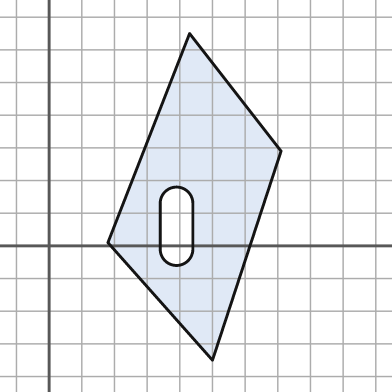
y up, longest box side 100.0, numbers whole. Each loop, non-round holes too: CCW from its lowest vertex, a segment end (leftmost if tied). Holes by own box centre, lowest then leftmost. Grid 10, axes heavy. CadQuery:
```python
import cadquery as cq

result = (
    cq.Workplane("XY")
    .moveTo(50.0, -35.0)
    .lineTo(71.0, 29.0)
    .lineTo(43.0, 65.0)
    .lineTo(18.0, 1.0)
    .close()
    .moveTo(34.0, -1.0)
    .threePointArc((39.0, -6.0), (44.0, -1.0))
    .lineTo(44.0, 13.0)
    .threePointArc((39.0, 18.0), (34.0, 13.0))
    .close()
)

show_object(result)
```